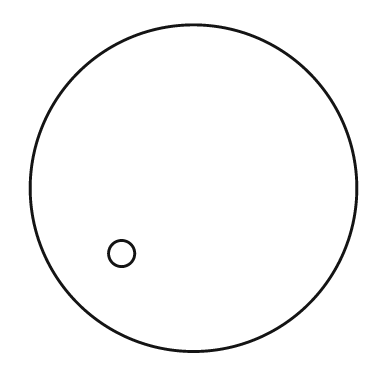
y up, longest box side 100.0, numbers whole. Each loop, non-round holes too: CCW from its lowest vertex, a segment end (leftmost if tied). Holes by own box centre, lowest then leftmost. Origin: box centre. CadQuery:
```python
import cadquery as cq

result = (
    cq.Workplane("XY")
    .moveTo(0.0, 0.0)
    .circle(50.0)
    .moveTo(-22.0, -20.0)
    .circle(4.0)
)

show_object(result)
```